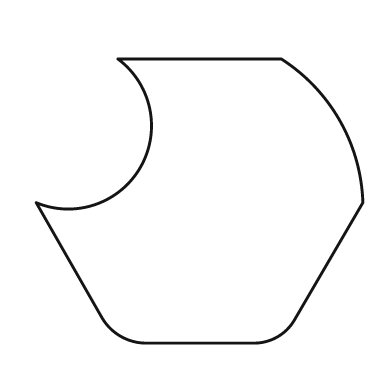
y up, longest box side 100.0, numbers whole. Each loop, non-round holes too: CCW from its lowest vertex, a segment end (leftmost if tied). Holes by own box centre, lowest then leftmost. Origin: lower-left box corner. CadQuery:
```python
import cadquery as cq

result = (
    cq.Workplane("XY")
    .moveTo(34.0, 0.0)
    .lineTo(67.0, 0.0)
    .threePointArc((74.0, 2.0), (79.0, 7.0))
    .lineTo(100.0, 43.0)
    .threePointArc((93.0, 68.0), (75.0, 87.0))
    .lineTo(25.0, 87.0)
    .threePointArc((32.0, 54.0), (0.0, 43.0))
    .lineTo(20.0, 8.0)
    .threePointArc((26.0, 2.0), (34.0, 0.0))
    .close()
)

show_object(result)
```